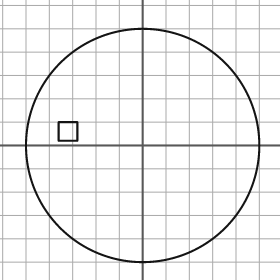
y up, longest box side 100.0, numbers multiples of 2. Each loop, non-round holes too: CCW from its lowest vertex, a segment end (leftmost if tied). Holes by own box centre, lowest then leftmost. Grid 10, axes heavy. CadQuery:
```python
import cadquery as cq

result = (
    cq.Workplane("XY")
    .moveTo(0.0, 0.0)
    .circle(50.0)
    .moveTo(-36.0, 2.0)
    .lineTo(-28.0, 2.0)
    .lineTo(-28.0, 10.0)
    .lineTo(-36.0, 10.0)
    .close()
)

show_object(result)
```